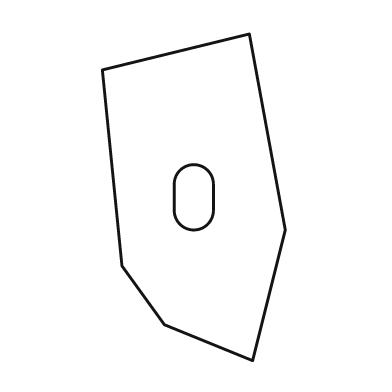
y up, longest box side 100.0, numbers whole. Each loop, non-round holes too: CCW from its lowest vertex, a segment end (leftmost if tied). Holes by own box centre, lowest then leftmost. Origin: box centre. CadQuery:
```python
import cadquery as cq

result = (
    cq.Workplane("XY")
    .moveTo(18.0, -50.0)
    .lineTo(28.0, -10.0)
    .lineTo(17.0, 50.0)
    .lineTo(-28.0, 39.0)
    .lineTo(-22.0, -21.0)
    .lineTo(-9.0, -39.0)
    .close()
    .moveTo(-6.0, -4.0)
    .threePointArc((0.0, -10.0), (6.0, -4.0))
    .lineTo(6.0, 4.0)
    .threePointArc((0.0, 10.0), (-6.0, 4.0))
    .close()
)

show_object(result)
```